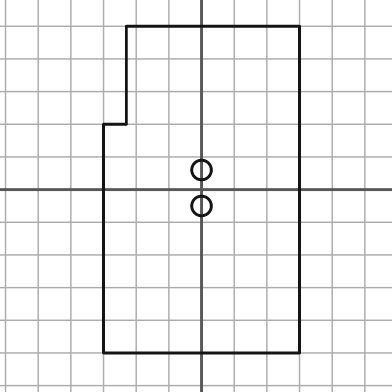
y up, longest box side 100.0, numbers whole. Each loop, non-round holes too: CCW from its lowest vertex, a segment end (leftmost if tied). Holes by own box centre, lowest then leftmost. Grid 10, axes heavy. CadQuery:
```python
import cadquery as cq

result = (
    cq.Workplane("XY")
    .moveTo(-30.0, -50.0)
    .lineTo(30.0, -50.0)
    .lineTo(30.0, 50.0)
    .lineTo(-23.0, 50.0)
    .lineTo(-23.0, 20.0)
    .lineTo(-30.0, 20.0)
    .close()
    .moveTo(0.0, -5.0)
    .circle(3.0)
    .moveTo(0.0, 6.0)
    .circle(3.0)
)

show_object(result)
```